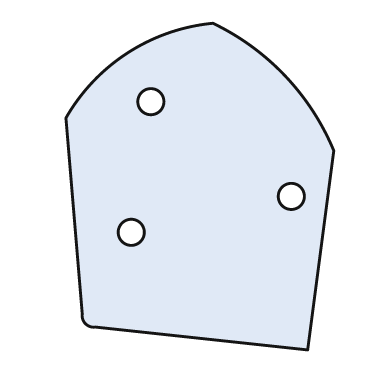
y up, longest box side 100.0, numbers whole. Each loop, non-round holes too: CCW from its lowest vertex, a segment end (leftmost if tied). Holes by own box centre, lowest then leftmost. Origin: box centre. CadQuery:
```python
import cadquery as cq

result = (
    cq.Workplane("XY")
    .moveTo(33.0, -50.0)
    .lineTo(41.0, 11.0)
    .threePointArc((26.0, 34.0), (4.0, 50.0))
    .threePointArc((-22.0, 41.0), (-41.0, 21.0))
    .lineTo(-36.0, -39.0)
    .threePointArc((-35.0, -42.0), (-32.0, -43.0))
    .close()
    .moveTo(-21.0, -14.0)
    .circle(4.0)
    .moveTo(28.0, -3.0)
    .circle(4.0)
    .moveTo(-15.0, 26.0)
    .circle(4.0)
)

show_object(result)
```